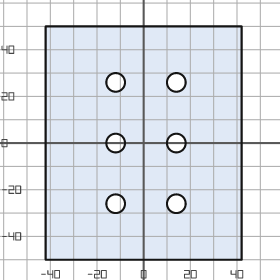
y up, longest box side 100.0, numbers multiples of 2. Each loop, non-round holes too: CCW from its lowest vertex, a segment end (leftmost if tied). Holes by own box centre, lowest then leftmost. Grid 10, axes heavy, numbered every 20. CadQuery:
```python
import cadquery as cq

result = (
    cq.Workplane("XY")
    .moveTo(-42.0, -50.0)
    .lineTo(42.0, -50.0)
    .lineTo(42.0, 50.0)
    .lineTo(-42.0, 50.0)
    .close()
    .moveTo(-12.0, -26.0)
    .circle(4.0)
    .moveTo(14.0, -26.0)
    .circle(4.0)
    .moveTo(-12.0, 0.0)
    .circle(4.0)
    .moveTo(14.0, 0.0)
    .circle(4.0)
    .moveTo(-12.0, 26.0)
    .circle(4.0)
    .moveTo(14.0, 26.0)
    .circle(4.0)
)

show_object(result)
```